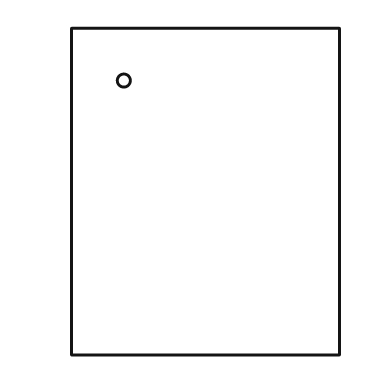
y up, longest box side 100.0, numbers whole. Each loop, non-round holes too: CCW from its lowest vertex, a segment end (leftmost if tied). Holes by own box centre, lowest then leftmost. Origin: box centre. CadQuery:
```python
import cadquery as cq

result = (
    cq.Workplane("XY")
    .moveTo(-41.0, -50.0)
    .lineTo(41.0, -50.0)
    .lineTo(41.0, 50.0)
    .lineTo(-41.0, 50.0)
    .close()
    .moveTo(-25.0, 34.0)
    .circle(2.0)
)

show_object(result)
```